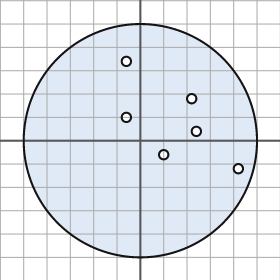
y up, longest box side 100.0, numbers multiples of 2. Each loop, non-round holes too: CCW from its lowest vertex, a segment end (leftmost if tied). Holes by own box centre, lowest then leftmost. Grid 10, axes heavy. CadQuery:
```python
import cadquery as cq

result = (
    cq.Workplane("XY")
    .moveTo(0.0, 0.0)
    .circle(50.0)
    .moveTo(42.0, -12.0)
    .circle(2.0)
    .moveTo(10.0, -6.0)
    .circle(2.0)
    .moveTo(24.0, 4.0)
    .circle(2.0)
    .moveTo(-6.0, 10.0)
    .circle(2.0)
    .moveTo(22.0, 18.0)
    .circle(2.0)
    .moveTo(-6.0, 34.0)
    .circle(2.0)
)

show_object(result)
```